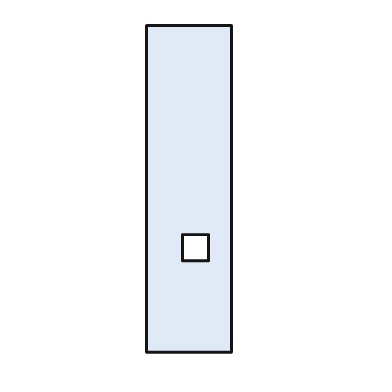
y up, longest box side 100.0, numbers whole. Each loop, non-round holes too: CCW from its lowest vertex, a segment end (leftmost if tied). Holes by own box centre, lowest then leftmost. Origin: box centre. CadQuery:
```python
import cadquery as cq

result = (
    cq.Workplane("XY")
    .moveTo(-13.0, -50.0)
    .lineTo(13.0, -50.0)
    .lineTo(13.0, 50.0)
    .lineTo(-13.0, 50.0)
    .close()
    .moveTo(-2.0, -22.0)
    .lineTo(6.0, -22.0)
    .lineTo(6.0, -14.0)
    .lineTo(-2.0, -14.0)
    .close()
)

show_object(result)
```